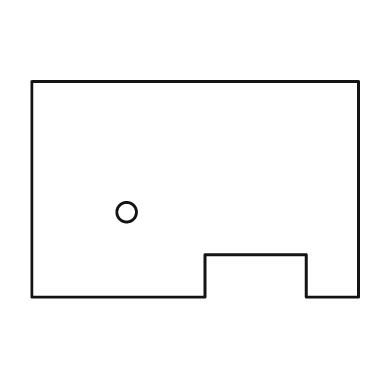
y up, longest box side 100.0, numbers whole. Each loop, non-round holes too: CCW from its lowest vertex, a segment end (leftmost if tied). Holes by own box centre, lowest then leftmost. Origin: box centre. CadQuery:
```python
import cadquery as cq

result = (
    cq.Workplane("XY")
    .moveTo(-50.0, -33.0)
    .lineTo(3.0, -33.0)
    .lineTo(3.0, -20.0)
    .lineTo(34.0, -20.0)
    .lineTo(34.0, -33.0)
    .lineTo(50.0, -33.0)
    .lineTo(50.0, 33.0)
    .lineTo(-50.0, 33.0)
    .close()
    .moveTo(-21.0, -7.0)
    .circle(3.0)
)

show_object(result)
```